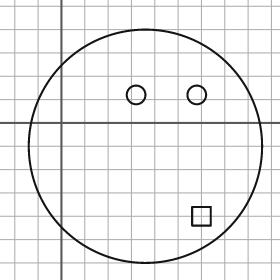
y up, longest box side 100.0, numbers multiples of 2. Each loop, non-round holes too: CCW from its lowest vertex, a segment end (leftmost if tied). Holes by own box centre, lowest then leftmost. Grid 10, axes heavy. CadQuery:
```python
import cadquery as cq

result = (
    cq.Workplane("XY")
    .moveTo(36.0, -10.0)
    .circle(50.0)
    .moveTo(56.0, -44.0)
    .lineTo(64.0, -44.0)
    .lineTo(64.0, -36.0)
    .lineTo(56.0, -36.0)
    .close()
    .moveTo(32.0, 12.0)
    .circle(4.0)
    .moveTo(58.0, 12.0)
    .circle(4.0)
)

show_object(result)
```